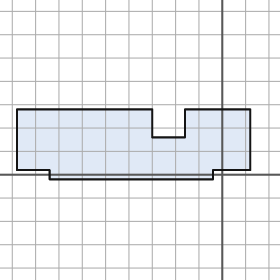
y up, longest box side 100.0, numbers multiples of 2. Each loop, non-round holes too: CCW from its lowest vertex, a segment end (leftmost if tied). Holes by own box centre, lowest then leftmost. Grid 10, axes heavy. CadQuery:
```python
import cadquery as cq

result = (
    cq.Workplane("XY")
    .moveTo(-74.0, -2.0)
    .lineTo(-4.0, -2.0)
    .lineTo(-4.0, 2.0)
    .lineTo(12.0, 2.0)
    .lineTo(12.0, 28.0)
    .lineTo(-16.0, 28.0)
    .lineTo(-16.0, 16.0)
    .lineTo(-30.0, 16.0)
    .lineTo(-30.0, 28.0)
    .lineTo(-88.0, 28.0)
    .lineTo(-88.0, 2.0)
    .lineTo(-74.0, 2.0)
    .close()
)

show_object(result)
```